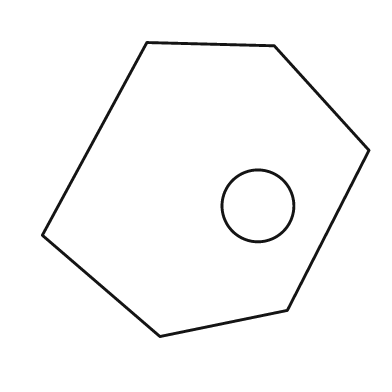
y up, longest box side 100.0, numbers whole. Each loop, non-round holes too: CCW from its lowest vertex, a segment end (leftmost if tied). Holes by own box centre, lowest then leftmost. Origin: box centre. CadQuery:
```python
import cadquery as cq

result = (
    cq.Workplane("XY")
    .moveTo(-14.0, -45.0)
    .lineTo(25.0, -37.0)
    .lineTo(50.0, 12.0)
    .lineTo(21.0, 44.0)
    .lineTo(-18.0, 45.0)
    .lineTo(-50.0, -14.0)
    .close()
    .moveTo(16.0, -5.0)
    .circle(11.0)
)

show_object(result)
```